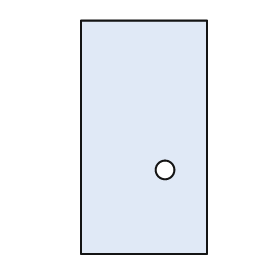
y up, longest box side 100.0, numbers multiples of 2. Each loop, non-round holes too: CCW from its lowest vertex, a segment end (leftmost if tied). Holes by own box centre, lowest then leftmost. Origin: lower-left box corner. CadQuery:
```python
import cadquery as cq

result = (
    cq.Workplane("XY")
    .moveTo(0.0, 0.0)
    .lineTo(54.0, 0.0)
    .lineTo(54.0, 100.0)
    .lineTo(0.0, 100.0)
    .close()
    .moveTo(36.0, 36.0)
    .circle(4.0)
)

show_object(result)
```